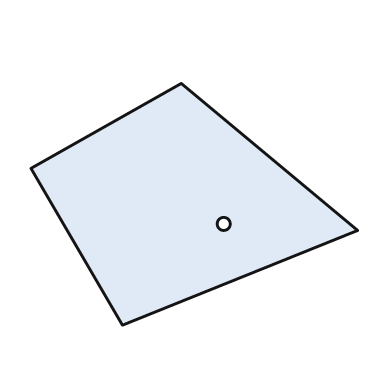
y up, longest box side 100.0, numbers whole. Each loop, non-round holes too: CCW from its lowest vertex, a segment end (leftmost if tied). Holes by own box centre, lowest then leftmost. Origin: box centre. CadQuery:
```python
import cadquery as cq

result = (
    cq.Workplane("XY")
    .moveTo(-22.0, -37.0)
    .lineTo(50.0, -8.0)
    .lineTo(-4.0, 37.0)
    .lineTo(-50.0, 11.0)
    .close()
    .moveTo(9.0, -6.0)
    .circle(2.0)
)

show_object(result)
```